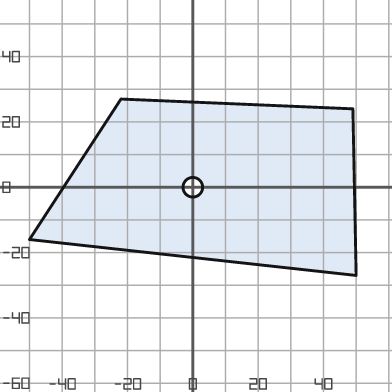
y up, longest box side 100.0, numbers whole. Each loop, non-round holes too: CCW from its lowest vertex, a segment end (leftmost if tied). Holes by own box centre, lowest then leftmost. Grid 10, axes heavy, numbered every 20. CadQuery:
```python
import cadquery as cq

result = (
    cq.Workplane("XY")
    .moveTo(50.0, -27.0)
    .lineTo(49.0, 24.0)
    .lineTo(-22.0, 27.0)
    .lineTo(-50.0, -16.0)
    .close()
    .moveTo(0.0, 0.0)
    .circle(3.0)
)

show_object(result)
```